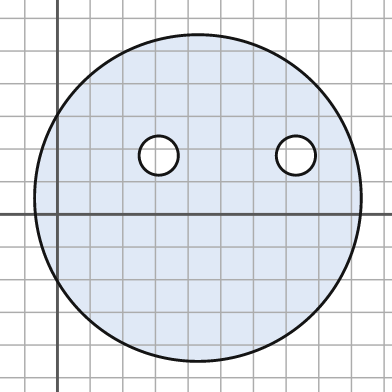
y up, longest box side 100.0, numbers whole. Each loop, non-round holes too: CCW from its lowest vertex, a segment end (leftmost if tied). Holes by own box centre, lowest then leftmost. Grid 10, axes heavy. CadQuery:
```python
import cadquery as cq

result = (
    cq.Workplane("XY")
    .moveTo(43.0, 5.0)
    .circle(50.0)
    .moveTo(31.0, 18.0)
    .circle(6.0)
    .moveTo(73.0, 18.0)
    .circle(6.0)
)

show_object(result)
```